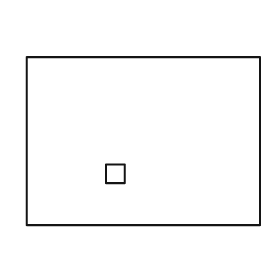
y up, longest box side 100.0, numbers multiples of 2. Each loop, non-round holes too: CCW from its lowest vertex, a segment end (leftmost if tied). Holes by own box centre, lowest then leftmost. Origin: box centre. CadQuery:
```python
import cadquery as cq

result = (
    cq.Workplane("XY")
    .moveTo(-50.0, -36.0)
    .lineTo(50.0, -36.0)
    .lineTo(50.0, 36.0)
    .lineTo(-50.0, 36.0)
    .close()
    .moveTo(-16.0, -18.0)
    .lineTo(-8.0, -18.0)
    .lineTo(-8.0, -10.0)
    .lineTo(-16.0, -10.0)
    .close()
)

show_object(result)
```